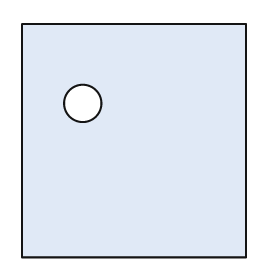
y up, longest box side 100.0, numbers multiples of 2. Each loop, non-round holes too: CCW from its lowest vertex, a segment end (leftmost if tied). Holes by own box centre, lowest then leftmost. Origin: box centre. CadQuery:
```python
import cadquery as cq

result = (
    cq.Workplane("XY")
    .moveTo(-48.0, -50.0)
    .lineTo(48.0, -50.0)
    .lineTo(48.0, 50.0)
    .lineTo(-48.0, 50.0)
    .close()
    .moveTo(-22.0, 16.0)
    .circle(8.0)
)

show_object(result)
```